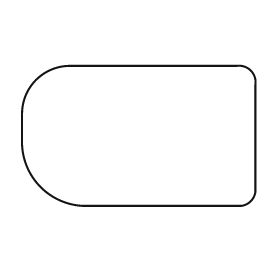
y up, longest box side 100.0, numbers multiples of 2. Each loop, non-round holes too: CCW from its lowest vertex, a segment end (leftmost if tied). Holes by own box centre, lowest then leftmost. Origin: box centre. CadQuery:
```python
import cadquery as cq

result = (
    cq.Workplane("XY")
    .moveTo(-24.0, -30.0)
    .lineTo(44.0, -30.0)
    .threePointArc((48.0, -28.0), (50.0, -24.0))
    .lineTo(50.0, 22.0)
    .threePointArc((48.0, 28.0), (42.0, 30.0))
    .lineTo(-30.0, 30.0)
    .threePointArc((-44.0, 24.0), (-50.0, 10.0))
    .lineTo(-50.0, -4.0)
    .threePointArc((-42.0, -22.0), (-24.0, -30.0))
    .close()
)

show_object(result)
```